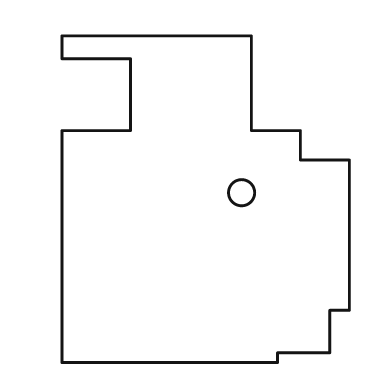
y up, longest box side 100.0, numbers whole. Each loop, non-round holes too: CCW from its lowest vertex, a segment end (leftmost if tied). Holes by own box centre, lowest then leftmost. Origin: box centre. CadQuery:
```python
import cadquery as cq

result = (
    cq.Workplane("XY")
    .moveTo(-44.0, -50.0)
    .lineTo(22.0, -50.0)
    .lineTo(22.0, -47.0)
    .lineTo(38.0, -47.0)
    .lineTo(38.0, -34.0)
    .lineTo(44.0, -34.0)
    .lineTo(44.0, 12.0)
    .lineTo(29.0, 12.0)
    .lineTo(29.0, 21.0)
    .lineTo(14.0, 21.0)
    .lineTo(14.0, 50.0)
    .lineTo(-44.0, 50.0)
    .lineTo(-44.0, 43.0)
    .lineTo(-23.0, 43.0)
    .lineTo(-23.0, 21.0)
    .lineTo(-44.0, 21.0)
    .close()
    .moveTo(11.0, 2.0)
    .circle(4.0)
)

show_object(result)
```